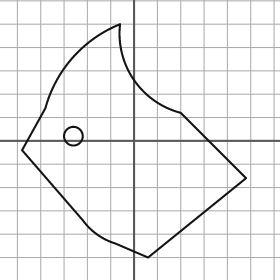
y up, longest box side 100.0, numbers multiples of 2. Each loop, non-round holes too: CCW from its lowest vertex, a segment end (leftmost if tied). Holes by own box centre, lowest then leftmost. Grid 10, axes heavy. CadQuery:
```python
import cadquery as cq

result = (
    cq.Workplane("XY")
    .moveTo(6.0, -50.0)
    .lineTo(48.0, -16.0)
    .lineTo(20.0, 12.0)
    .threePointArc((0.0, 26.0), (-6.0, 50.0))
    .threePointArc((-26.0, 36.0), (-38.0, 14.0))
    .lineTo(-48.0, -4.0)
    .lineTo(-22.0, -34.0)
    .threePointArc((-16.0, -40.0), (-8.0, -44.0))
    .close()
    .moveTo(-26.0, 2.0)
    .circle(4.0)
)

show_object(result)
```